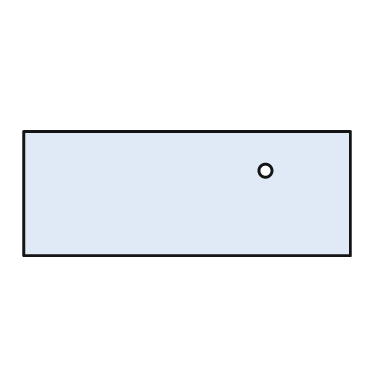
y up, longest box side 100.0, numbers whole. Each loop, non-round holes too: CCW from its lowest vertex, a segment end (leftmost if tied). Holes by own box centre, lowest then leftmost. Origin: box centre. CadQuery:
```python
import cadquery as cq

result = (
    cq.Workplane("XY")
    .moveTo(-50.0, -19.0)
    .lineTo(50.0, -19.0)
    .lineTo(50.0, 19.0)
    .lineTo(-50.0, 19.0)
    .close()
    .moveTo(24.0, 7.0)
    .circle(2.0)
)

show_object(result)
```